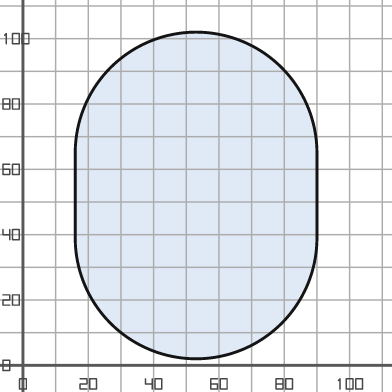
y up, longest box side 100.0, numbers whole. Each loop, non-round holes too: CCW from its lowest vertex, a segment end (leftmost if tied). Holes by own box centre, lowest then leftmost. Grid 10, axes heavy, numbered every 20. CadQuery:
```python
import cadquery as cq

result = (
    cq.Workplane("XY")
    .moveTo(16.0, 39.0)
    .threePointArc((53.0, 2.0), (90.0, 39.0))
    .lineTo(90.0, 65.0)
    .threePointArc((53.0, 102.0), (16.0, 65.0))
    .close()
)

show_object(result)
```